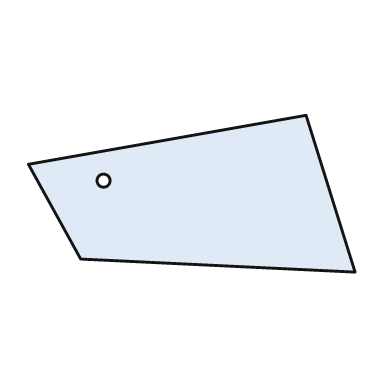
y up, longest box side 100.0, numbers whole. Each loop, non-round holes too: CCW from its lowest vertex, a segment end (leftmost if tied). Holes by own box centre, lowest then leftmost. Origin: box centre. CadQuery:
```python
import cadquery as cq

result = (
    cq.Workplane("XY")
    .moveTo(50.0, -24.0)
    .lineTo(35.0, 24.0)
    .lineTo(-50.0, 9.0)
    .lineTo(-34.0, -20.0)
    .close()
    .moveTo(-27.0, 4.0)
    .circle(2.0)
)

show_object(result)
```